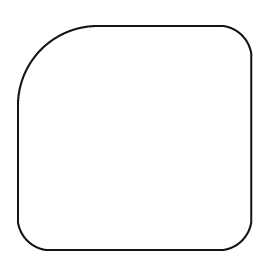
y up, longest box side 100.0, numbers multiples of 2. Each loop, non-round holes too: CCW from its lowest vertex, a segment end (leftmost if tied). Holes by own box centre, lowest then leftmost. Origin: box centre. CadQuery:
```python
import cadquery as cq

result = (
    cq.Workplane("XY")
    .moveTo(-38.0, -48.0)
    .lineTo(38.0, -48.0)
    .threePointArc((46.0, -44.0), (50.0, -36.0))
    .lineTo(50.0, 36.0)
    .threePointArc((46.0, 44.0), (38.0, 48.0))
    .lineTo(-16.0, 48.0)
    .threePointArc((-40.0, 38.0), (-50.0, 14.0))
    .lineTo(-50.0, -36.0)
    .threePointArc((-46.0, -44.0), (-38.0, -48.0))
    .close()
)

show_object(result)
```